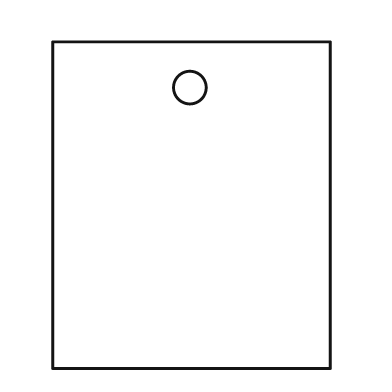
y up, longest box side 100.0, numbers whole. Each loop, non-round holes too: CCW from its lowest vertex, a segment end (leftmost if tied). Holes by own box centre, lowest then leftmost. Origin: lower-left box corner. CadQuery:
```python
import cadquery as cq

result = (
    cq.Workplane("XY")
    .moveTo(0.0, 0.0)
    .lineTo(85.0, 0.0)
    .lineTo(85.0, 100.0)
    .lineTo(0.0, 100.0)
    .close()
    .moveTo(42.0, 86.0)
    .circle(5.0)
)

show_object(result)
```